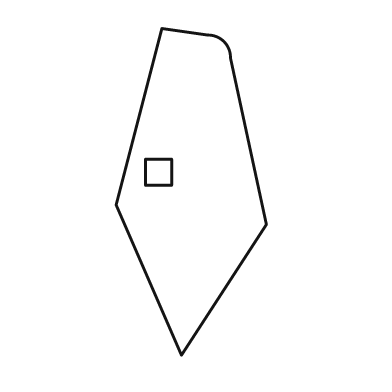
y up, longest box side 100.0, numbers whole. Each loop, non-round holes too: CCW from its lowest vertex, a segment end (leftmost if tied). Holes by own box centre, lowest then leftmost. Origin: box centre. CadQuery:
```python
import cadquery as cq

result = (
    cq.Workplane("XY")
    .moveTo(-3.0, -50.0)
    .lineTo(23.0, -10.0)
    .lineTo(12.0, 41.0)
    .threePointArc((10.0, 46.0), (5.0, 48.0))
    .lineTo(-9.0, 50.0)
    .lineTo(-23.0, -4.0)
    .close()
    .moveTo(-14.0, 2.0)
    .lineTo(-6.0, 2.0)
    .lineTo(-6.0, 10.0)
    .lineTo(-14.0, 10.0)
    .close()
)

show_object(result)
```